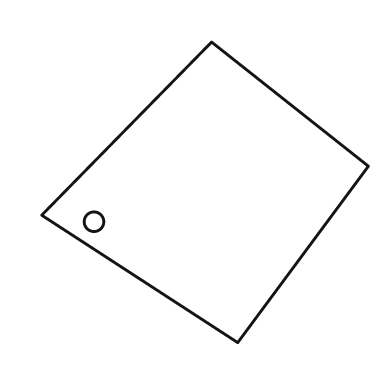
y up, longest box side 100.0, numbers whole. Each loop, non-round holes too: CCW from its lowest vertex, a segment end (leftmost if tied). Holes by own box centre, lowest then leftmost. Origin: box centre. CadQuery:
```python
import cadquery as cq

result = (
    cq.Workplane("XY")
    .moveTo(10.0, -46.0)
    .lineTo(50.0, 8.0)
    .lineTo(2.0, 46.0)
    .lineTo(-50.0, -7.0)
    .close()
    .moveTo(-34.0, -9.0)
    .circle(3.0)
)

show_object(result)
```